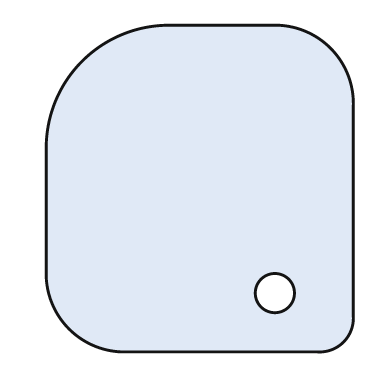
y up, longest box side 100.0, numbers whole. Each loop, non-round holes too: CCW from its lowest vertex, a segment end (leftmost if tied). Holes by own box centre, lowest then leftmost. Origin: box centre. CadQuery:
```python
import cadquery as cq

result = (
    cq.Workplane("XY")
    .moveTo(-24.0, -50.0)
    .lineTo(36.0, -50.0)
    .threePointArc((44.0, -47.0), (47.0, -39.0))
    .lineTo(47.0, 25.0)
    .threePointArc((40.0, 43.0), (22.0, 50.0))
    .lineTo(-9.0, 50.0)
    .threePointArc((-36.0, 39.0), (-47.0, 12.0))
    .lineTo(-47.0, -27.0)
    .threePointArc((-40.0, -43.0), (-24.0, -50.0))
    .close()
    .moveTo(23.0, -32.0)
    .circle(6.0)
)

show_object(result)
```